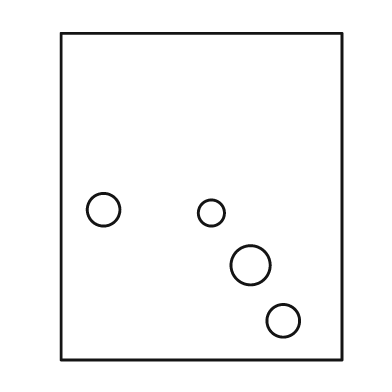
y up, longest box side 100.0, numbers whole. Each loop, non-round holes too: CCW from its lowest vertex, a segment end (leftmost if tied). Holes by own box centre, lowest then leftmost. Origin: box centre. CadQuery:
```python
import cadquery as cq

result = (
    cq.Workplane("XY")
    .moveTo(-43.0, -50.0)
    .lineTo(43.0, -50.0)
    .lineTo(43.0, 50.0)
    .lineTo(-43.0, 50.0)
    .close()
    .moveTo(25.0, -38.0)
    .circle(5.0)
    .moveTo(15.0, -21.0)
    .circle(6.0)
    .moveTo(3.0, -5.0)
    .circle(4.0)
    .moveTo(-30.0, -4.0)
    .circle(5.0)
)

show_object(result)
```